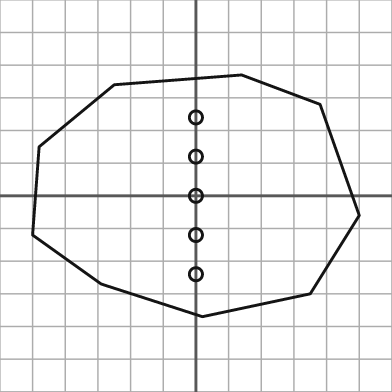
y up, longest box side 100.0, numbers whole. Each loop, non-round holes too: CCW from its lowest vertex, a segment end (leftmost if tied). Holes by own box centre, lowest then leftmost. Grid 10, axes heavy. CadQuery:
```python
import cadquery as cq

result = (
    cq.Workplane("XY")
    .moveTo(2.0, -37.0)
    .lineTo(35.0, -30.0)
    .lineTo(50.0, -6.0)
    .lineTo(38.0, 28.0)
    .lineTo(14.0, 37.0)
    .lineTo(-25.0, 34.0)
    .lineTo(-48.0, 15.0)
    .lineTo(-50.0, -12.0)
    .lineTo(-29.0, -27.0)
    .close()
    .moveTo(0.0, -24.0)
    .circle(2.0)
    .moveTo(0.0, -12.0)
    .circle(2.0)
    .moveTo(0.0, 0.0)
    .circle(2.0)
    .moveTo(0.0, 12.0)
    .circle(2.0)
    .moveTo(0.0, 24.0)
    .circle(2.0)
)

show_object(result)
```